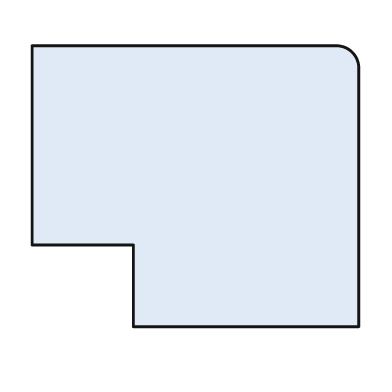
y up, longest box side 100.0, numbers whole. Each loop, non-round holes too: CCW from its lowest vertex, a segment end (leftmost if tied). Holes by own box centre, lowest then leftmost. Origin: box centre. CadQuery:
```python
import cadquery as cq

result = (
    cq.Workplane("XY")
    .moveTo(-19.0, -43.0)
    .lineTo(50.0, -43.0)
    .lineTo(50.0, 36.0)
    .threePointArc((48.0, 41.0), (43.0, 43.0))
    .lineTo(-50.0, 43.0)
    .lineTo(-50.0, -18.0)
    .lineTo(-19.0, -18.0)
    .close()
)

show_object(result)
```